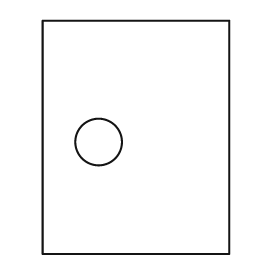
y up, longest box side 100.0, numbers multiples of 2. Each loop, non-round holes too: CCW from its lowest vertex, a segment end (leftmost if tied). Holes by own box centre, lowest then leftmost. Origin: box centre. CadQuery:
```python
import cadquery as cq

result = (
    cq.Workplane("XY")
    .moveTo(-40.0, -50.0)
    .lineTo(40.0, -50.0)
    .lineTo(40.0, 50.0)
    .lineTo(-40.0, 50.0)
    .close()
    .moveTo(-16.0, -2.0)
    .circle(10.0)
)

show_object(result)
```